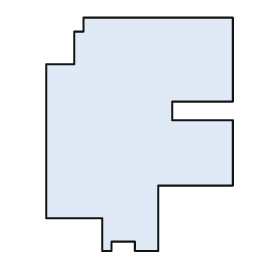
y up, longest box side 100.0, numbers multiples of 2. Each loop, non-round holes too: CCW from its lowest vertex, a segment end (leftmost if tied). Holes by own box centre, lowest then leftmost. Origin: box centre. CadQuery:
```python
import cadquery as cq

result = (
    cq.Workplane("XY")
    .moveTo(-16.0, -50.0)
    .lineTo(-12.0, -50.0)
    .lineTo(-12.0, -46.0)
    .lineTo(-2.0, -46.0)
    .lineTo(-2.0, -50.0)
    .lineTo(8.0, -50.0)
    .lineTo(8.0, -22.0)
    .lineTo(40.0, -22.0)
    .lineTo(40.0, 6.0)
    .lineTo(14.0, 6.0)
    .lineTo(14.0, 14.0)
    .lineTo(40.0, 14.0)
    .lineTo(40.0, 50.0)
    .lineTo(-24.0, 50.0)
    .lineTo(-24.0, 44.0)
    .lineTo(-28.0, 44.0)
    .lineTo(-28.0, 30.0)
    .lineTo(-40.0, 30.0)
    .lineTo(-40.0, -36.0)
    .lineTo(-16.0, -36.0)
    .close()
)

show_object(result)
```